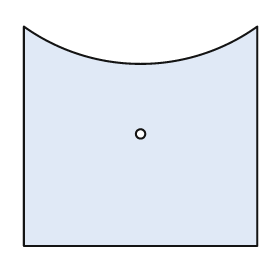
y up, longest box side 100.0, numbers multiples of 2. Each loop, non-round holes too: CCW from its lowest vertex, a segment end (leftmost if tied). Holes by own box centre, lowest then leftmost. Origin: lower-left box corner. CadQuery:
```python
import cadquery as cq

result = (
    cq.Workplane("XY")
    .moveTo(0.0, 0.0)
    .lineTo(100.0, 0.0)
    .lineTo(100.0, 94.0)
    .threePointArc((50.0, 78.0), (0.0, 94.0))
    .close()
    .moveTo(50.0, 48.0)
    .circle(2.0)
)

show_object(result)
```